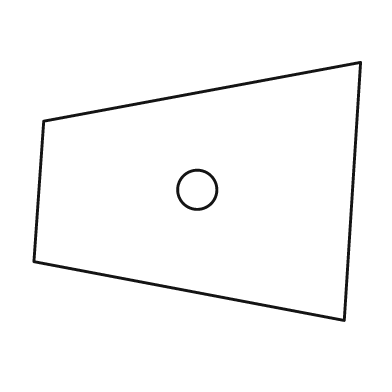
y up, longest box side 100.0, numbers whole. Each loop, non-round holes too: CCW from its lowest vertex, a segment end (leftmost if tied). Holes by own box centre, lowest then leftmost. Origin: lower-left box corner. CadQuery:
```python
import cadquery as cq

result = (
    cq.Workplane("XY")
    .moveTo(95.0, 0.0)
    .lineTo(100.0, 79.0)
    .lineTo(3.0, 61.0)
    .lineTo(0.0, 18.0)
    .close()
    .moveTo(50.0, 40.0)
    .circle(6.0)
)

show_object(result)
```